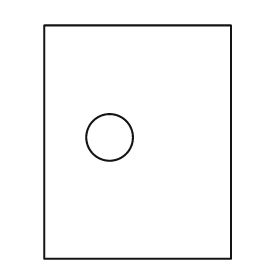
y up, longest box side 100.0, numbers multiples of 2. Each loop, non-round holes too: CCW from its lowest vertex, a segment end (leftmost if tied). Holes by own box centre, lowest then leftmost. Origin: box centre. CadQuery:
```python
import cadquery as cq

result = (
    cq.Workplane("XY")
    .moveTo(-40.0, -50.0)
    .lineTo(40.0, -50.0)
    .lineTo(40.0, 50.0)
    .lineTo(-40.0, 50.0)
    .close()
    .moveTo(-12.0, 2.0)
    .circle(10.0)
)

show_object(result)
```